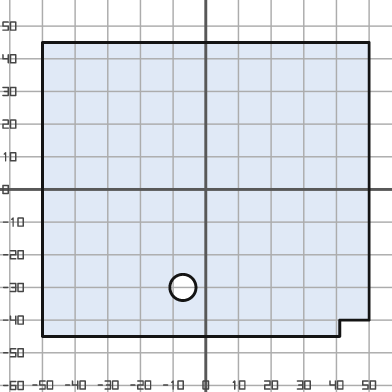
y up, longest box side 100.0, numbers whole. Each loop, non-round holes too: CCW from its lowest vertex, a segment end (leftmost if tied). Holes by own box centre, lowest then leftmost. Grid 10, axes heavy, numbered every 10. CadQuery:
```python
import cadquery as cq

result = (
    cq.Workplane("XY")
    .moveTo(-50.0, -45.0)
    .lineTo(41.0, -45.0)
    .lineTo(41.0, -40.0)
    .lineTo(50.0, -40.0)
    .lineTo(50.0, 45.0)
    .lineTo(-50.0, 45.0)
    .close()
    .moveTo(-7.0, -30.0)
    .circle(4.0)
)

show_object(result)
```